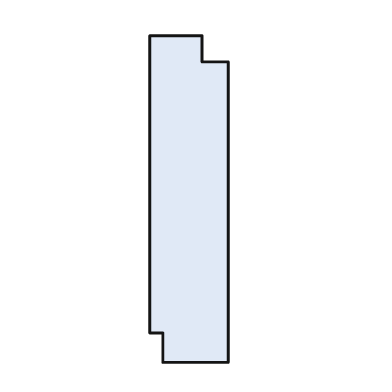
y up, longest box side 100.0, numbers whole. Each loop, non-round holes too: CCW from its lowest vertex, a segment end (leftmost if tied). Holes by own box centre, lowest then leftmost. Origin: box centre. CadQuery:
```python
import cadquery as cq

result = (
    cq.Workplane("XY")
    .moveTo(-8.0, -50.0)
    .lineTo(12.0, -50.0)
    .lineTo(12.0, 42.0)
    .lineTo(4.0, 42.0)
    .lineTo(4.0, 50.0)
    .lineTo(-12.0, 50.0)
    .lineTo(-12.0, -41.0)
    .lineTo(-8.0, -41.0)
    .close()
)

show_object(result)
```